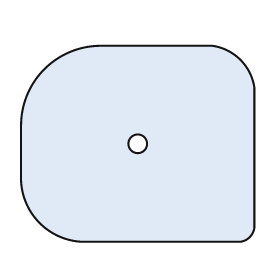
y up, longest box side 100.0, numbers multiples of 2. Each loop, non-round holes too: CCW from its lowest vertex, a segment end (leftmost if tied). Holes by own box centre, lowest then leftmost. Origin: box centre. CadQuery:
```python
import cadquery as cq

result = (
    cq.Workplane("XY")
    .moveTo(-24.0, -42.0)
    .lineTo(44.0, -42.0)
    .threePointArc((48.0, -40.0), (50.0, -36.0))
    .lineTo(50.0, 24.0)
    .threePointArc((44.0, 36.0), (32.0, 42.0))
    .lineTo(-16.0, 42.0)
    .threePointArc((-40.0, 32.0), (-50.0, 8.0))
    .lineTo(-50.0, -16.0)
    .threePointArc((-42.0, -34.0), (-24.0, -42.0))
    .close()
    .moveTo(0.0, 0.0)
    .circle(4.0)
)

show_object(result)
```